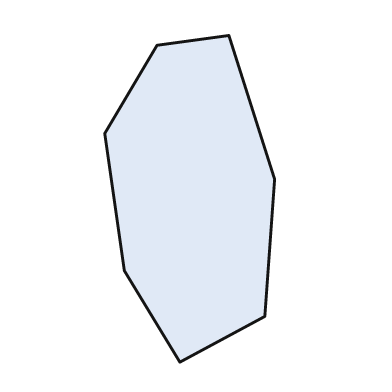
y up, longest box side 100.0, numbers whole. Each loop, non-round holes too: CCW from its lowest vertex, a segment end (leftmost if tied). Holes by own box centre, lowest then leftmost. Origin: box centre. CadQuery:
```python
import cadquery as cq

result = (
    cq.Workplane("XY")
    .moveTo(-3.0, -50.0)
    .lineTo(23.0, -36.0)
    .lineTo(26.0, 6.0)
    .lineTo(12.0, 50.0)
    .lineTo(-10.0, 47.0)
    .lineTo(-26.0, 20.0)
    .lineTo(-20.0, -22.0)
    .close()
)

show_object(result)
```